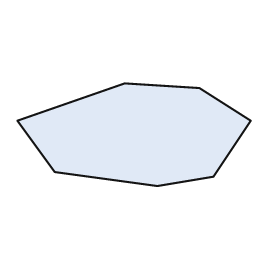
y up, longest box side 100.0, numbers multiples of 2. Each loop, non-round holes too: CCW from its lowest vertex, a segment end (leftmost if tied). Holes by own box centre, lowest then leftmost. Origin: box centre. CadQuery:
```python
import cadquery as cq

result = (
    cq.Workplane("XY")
    .moveTo(10.0, -22.0)
    .lineTo(34.0, -18.0)
    .lineTo(50.0, 6.0)
    .lineTo(28.0, 20.0)
    .lineTo(-4.0, 22.0)
    .lineTo(-50.0, 6.0)
    .lineTo(-34.0, -16.0)
    .close()
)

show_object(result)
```